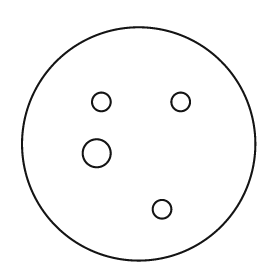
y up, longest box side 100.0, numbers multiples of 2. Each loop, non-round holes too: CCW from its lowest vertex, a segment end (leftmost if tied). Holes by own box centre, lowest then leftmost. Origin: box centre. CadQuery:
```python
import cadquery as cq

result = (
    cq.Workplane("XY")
    .moveTo(0.0, 0.0)
    .circle(50.0)
    .moveTo(10.0, -28.0)
    .circle(4.0)
    .moveTo(-18.0, -4.0)
    .circle(6.0)
    .moveTo(-16.0, 18.0)
    .circle(4.0)
    .moveTo(18.0, 18.0)
    .circle(4.0)
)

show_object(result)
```